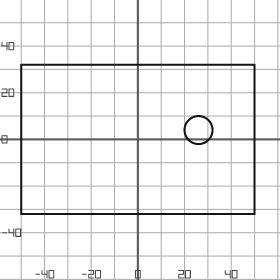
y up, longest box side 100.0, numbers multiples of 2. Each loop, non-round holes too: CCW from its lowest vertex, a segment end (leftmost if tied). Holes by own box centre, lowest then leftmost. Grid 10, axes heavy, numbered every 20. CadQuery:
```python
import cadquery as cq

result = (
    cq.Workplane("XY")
    .moveTo(-50.0, -32.0)
    .lineTo(50.0, -32.0)
    .lineTo(50.0, 32.0)
    .lineTo(-50.0, 32.0)
    .close()
    .moveTo(26.0, 4.0)
    .circle(6.0)
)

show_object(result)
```